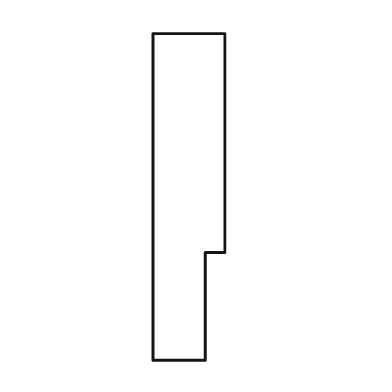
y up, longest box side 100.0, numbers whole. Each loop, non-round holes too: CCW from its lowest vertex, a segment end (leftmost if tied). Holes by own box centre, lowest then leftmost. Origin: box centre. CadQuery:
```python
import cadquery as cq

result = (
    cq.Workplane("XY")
    .moveTo(-11.0, -50.0)
    .lineTo(5.0, -50.0)
    .lineTo(5.0, -17.0)
    .lineTo(11.0, -17.0)
    .lineTo(11.0, 50.0)
    .lineTo(-11.0, 50.0)
    .close()
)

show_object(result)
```